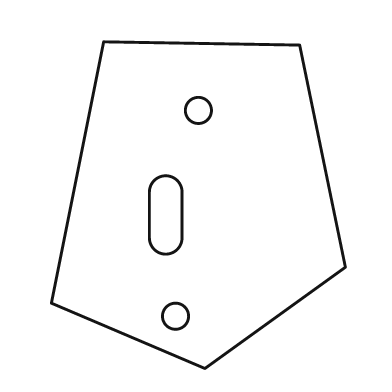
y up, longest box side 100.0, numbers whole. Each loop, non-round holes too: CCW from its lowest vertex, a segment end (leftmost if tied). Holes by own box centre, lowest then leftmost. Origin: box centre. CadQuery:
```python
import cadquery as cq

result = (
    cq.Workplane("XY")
    .moveTo(2.0, -50.0)
    .lineTo(45.0, -19.0)
    .lineTo(31.0, 49.0)
    .lineTo(-29.0, 50.0)
    .lineTo(-45.0, -30.0)
    .close()
    .moveTo(-7.0, -34.0)
    .circle(4.0)
    .moveTo(-15.0, -10.0)
    .threePointArc((-10.0, -15.0), (-5.0, -10.0))
    .lineTo(-5.0, 4.0)
    .threePointArc((-10.0, 9.0), (-15.0, 4.0))
    .close()
    .moveTo(0.0, 29.0)
    .circle(4.0)
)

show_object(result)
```